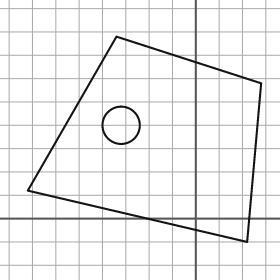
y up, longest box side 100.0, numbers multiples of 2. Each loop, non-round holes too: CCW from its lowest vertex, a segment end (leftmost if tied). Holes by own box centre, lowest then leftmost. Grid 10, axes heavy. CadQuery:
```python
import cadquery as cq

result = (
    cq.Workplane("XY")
    .moveTo(22.0, -10.0)
    .lineTo(28.0, 58.0)
    .lineTo(-34.0, 78.0)
    .lineTo(-72.0, 12.0)
    .close()
    .moveTo(-32.0, 40.0)
    .circle(8.0)
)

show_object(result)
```